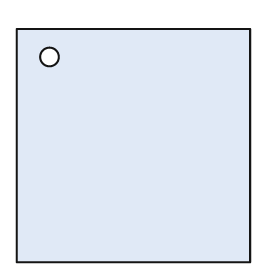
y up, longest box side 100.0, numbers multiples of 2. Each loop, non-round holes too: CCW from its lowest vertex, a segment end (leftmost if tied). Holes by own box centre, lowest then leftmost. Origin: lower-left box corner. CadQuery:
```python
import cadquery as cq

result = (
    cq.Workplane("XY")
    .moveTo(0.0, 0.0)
    .lineTo(100.0, 0.0)
    .lineTo(100.0, 100.0)
    .lineTo(0.0, 100.0)
    .close()
    .moveTo(14.0, 88.0)
    .circle(4.0)
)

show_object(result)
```